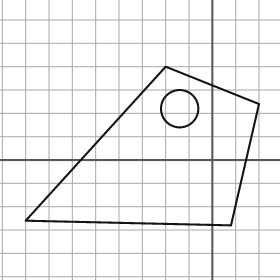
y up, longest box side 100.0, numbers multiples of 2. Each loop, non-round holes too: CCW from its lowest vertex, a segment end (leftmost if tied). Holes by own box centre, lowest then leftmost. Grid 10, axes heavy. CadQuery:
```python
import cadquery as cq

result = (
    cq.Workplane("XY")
    .moveTo(8.0, -28.0)
    .lineTo(20.0, 24.0)
    .lineTo(-20.0, 40.0)
    .lineTo(-80.0, -26.0)
    .close()
    .moveTo(-14.0, 22.0)
    .circle(8.0)
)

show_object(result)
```